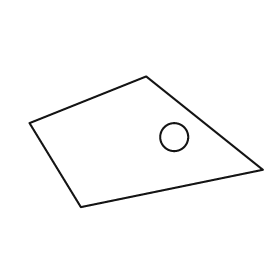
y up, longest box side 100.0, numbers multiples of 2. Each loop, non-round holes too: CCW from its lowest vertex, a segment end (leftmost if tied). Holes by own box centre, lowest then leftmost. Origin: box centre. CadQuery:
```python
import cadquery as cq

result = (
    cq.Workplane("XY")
    .moveTo(-28.0, -28.0)
    .lineTo(50.0, -12.0)
    .lineTo(0.0, 28.0)
    .lineTo(-50.0, 8.0)
    .close()
    .moveTo(12.0, 2.0)
    .circle(6.0)
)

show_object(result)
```